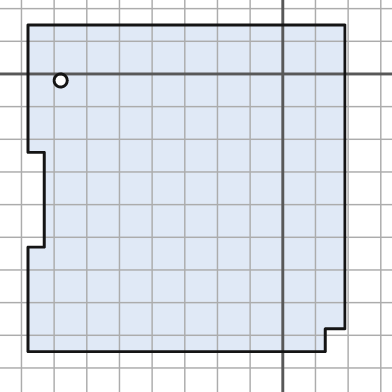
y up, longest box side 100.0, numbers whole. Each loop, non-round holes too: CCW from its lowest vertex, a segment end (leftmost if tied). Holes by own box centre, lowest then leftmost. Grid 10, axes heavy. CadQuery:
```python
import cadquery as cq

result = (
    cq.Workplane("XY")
    .moveTo(-78.0, -85.0)
    .lineTo(13.0, -85.0)
    .lineTo(13.0, -78.0)
    .lineTo(19.0, -78.0)
    .lineTo(19.0, 15.0)
    .lineTo(-78.0, 15.0)
    .lineTo(-78.0, -24.0)
    .lineTo(-73.0, -24.0)
    .lineTo(-73.0, -53.0)
    .lineTo(-78.0, -53.0)
    .close()
    .moveTo(-68.0, -2.0)
    .circle(2.0)
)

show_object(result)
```